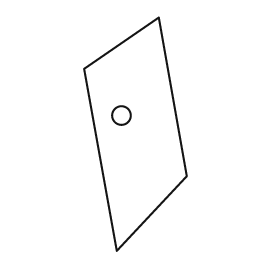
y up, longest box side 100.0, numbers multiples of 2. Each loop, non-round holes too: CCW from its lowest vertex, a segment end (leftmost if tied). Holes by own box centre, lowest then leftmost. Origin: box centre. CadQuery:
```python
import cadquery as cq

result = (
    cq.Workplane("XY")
    .moveTo(-8.0, -50.0)
    .lineTo(22.0, -18.0)
    .lineTo(10.0, 50.0)
    .lineTo(-22.0, 28.0)
    .close()
    .moveTo(-6.0, 8.0)
    .circle(4.0)
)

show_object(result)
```